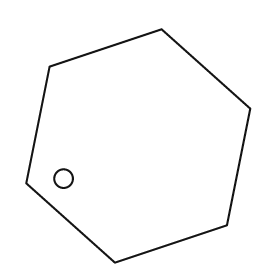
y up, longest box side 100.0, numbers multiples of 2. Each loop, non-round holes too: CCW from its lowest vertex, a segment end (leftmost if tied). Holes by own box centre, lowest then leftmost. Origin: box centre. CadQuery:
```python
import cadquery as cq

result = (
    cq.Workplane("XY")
    .moveTo(-10.0, -50.0)
    .lineTo(38.0, -34.0)
    .lineTo(48.0, 16.0)
    .lineTo(10.0, 50.0)
    .lineTo(-38.0, 34.0)
    .lineTo(-48.0, -16.0)
    .close()
    .moveTo(-32.0, -14.0)
    .circle(4.0)
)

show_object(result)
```